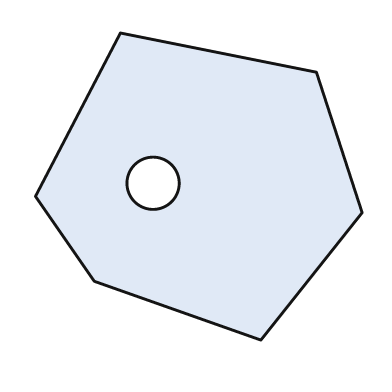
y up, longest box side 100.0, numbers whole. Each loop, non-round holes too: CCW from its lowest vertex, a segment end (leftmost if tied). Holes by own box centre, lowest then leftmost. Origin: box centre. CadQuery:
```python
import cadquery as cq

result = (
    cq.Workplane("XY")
    .moveTo(19.0, -47.0)
    .lineTo(50.0, -8.0)
    .lineTo(36.0, 35.0)
    .lineTo(-24.0, 47.0)
    .lineTo(-50.0, -3.0)
    .lineTo(-32.0, -29.0)
    .close()
    .moveTo(-14.0, 1.0)
    .circle(8.0)
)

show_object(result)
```